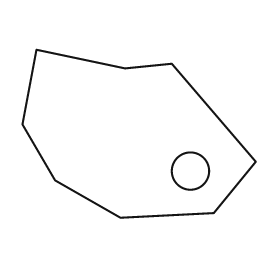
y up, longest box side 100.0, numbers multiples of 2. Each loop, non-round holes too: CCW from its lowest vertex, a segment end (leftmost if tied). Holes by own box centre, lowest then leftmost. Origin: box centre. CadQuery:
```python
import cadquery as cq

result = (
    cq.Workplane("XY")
    .moveTo(-8.0, -36.0)
    .lineTo(32.0, -34.0)
    .lineTo(50.0, -12.0)
    .lineTo(14.0, 30.0)
    .lineTo(-6.0, 28.0)
    .lineTo(-44.0, 36.0)
    .lineTo(-50.0, 4.0)
    .lineTo(-36.0, -20.0)
    .close()
    .moveTo(22.0, -16.0)
    .circle(8.0)
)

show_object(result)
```